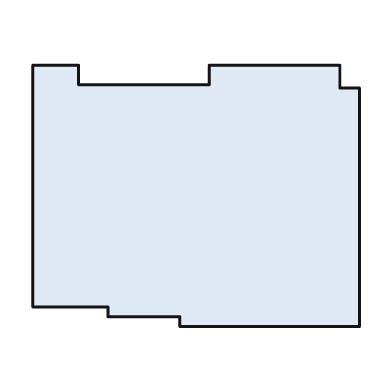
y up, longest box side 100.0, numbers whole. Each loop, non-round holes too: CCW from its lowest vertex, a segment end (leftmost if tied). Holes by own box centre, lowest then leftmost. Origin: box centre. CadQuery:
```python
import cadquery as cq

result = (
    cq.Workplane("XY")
    .moveTo(-5.0, -40.0)
    .lineTo(50.0, -40.0)
    .lineTo(50.0, 33.0)
    .lineTo(44.0, 33.0)
    .lineTo(44.0, 40.0)
    .lineTo(4.0, 40.0)
    .lineTo(4.0, 34.0)
    .lineTo(-36.0, 34.0)
    .lineTo(-36.0, 40.0)
    .lineTo(-50.0, 40.0)
    .lineTo(-50.0, -34.0)
    .lineTo(-27.0, -34.0)
    .lineTo(-27.0, -37.0)
    .lineTo(-5.0, -37.0)
    .close()
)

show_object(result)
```